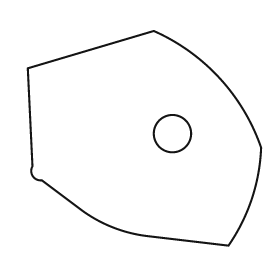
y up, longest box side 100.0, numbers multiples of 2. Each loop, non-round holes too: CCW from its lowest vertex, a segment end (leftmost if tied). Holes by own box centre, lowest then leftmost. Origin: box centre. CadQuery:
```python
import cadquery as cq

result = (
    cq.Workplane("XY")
    .moveTo(36.0, -46.0)
    .threePointArc((46.0, -26.0), (50.0, -4.0))
    .threePointArc((32.0, 26.0), (4.0, 46.0))
    .lineTo(-50.0, 30.0)
    .lineTo(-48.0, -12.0)
    .threePointArc((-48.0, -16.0), (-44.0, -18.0))
    .lineTo(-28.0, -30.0)
    .threePointArc((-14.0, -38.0), (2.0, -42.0))
    .close()
    .moveTo(12.0, 2.0)
    .circle(8.0)
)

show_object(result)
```